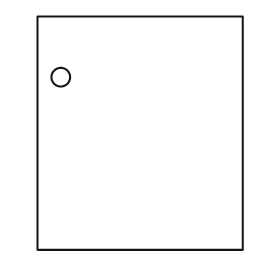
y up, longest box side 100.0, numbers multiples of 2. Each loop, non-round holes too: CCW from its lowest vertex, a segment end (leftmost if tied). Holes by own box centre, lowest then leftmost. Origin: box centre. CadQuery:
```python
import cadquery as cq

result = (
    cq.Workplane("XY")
    .moveTo(-44.0, -50.0)
    .lineTo(44.0, -50.0)
    .lineTo(44.0, 50.0)
    .lineTo(-44.0, 50.0)
    .close()
    .moveTo(-34.0, 24.0)
    .circle(4.0)
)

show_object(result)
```